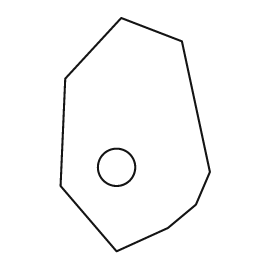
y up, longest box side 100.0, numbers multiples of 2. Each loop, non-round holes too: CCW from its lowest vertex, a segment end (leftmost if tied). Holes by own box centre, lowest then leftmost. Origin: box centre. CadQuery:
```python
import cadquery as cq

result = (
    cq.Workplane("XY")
    .moveTo(-8.0, -50.0)
    .lineTo(14.0, -40.0)
    .lineTo(26.0, -30.0)
    .lineTo(32.0, -16.0)
    .lineTo(20.0, 40.0)
    .lineTo(-6.0, 50.0)
    .lineTo(-30.0, 24.0)
    .lineTo(-32.0, -22.0)
    .close()
    .moveTo(-8.0, -14.0)
    .circle(8.0)
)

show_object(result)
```